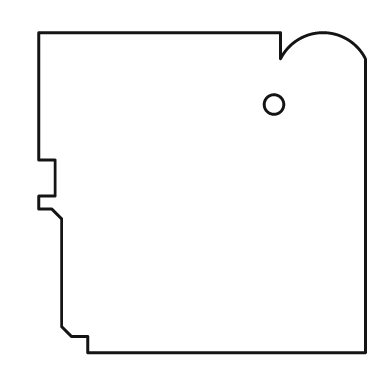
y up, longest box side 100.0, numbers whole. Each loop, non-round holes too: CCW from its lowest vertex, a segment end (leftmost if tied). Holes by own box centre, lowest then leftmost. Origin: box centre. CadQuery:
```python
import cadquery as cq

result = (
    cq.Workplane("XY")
    .moveTo(-35.0, -49.0)
    .lineTo(50.0, -49.0)
    .lineTo(50.0, 41.0)
    .threePointArc((37.0, 49.0), (24.0, 41.0))
    .lineTo(24.0, 49.0)
    .lineTo(-50.0, 49.0)
    .lineTo(-50.0, 10.0)
    .lineTo(-45.0, 10.0)
    .lineTo(-45.0, -1.0)
    .lineTo(-50.0, -1.0)
    .lineTo(-50.0, -5.0)
    .lineTo(-46.0, -5.0)
    .lineTo(-43.0, -8.0)
    .lineTo(-43.0, -41.0)
    .lineTo(-40.0, -44.0)
    .lineTo(-35.0, -44.0)
    .close()
    .moveTo(22.0, 27.0)
    .circle(3.0)
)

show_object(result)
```